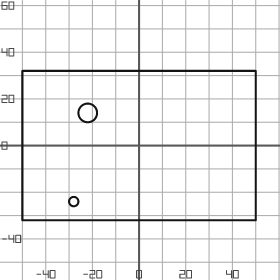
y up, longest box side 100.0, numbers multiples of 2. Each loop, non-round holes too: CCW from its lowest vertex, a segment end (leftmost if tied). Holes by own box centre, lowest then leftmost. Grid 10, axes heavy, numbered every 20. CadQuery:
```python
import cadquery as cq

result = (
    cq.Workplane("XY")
    .moveTo(-50.0, -32.0)
    .lineTo(50.0, -32.0)
    .lineTo(50.0, 32.0)
    .lineTo(-50.0, 32.0)
    .close()
    .moveTo(-28.0, -24.0)
    .circle(2.0)
    .moveTo(-22.0, 14.0)
    .circle(4.0)
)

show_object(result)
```